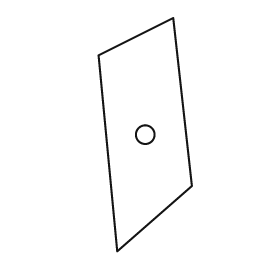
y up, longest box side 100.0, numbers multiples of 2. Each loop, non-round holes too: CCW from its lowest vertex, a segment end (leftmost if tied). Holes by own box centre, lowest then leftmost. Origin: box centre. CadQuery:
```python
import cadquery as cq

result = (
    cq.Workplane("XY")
    .moveTo(-12.0, -50.0)
    .lineTo(20.0, -22.0)
    .lineTo(12.0, 50.0)
    .lineTo(-20.0, 34.0)
    .close()
    .moveTo(0.0, 0.0)
    .circle(4.0)
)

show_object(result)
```